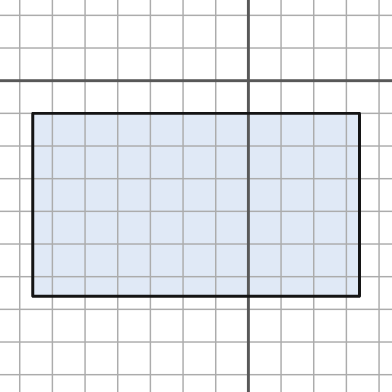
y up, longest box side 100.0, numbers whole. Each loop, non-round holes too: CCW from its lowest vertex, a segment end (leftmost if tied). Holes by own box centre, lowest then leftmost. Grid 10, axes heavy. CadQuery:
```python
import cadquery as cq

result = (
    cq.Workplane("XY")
    .moveTo(-66.0, -66.0)
    .lineTo(34.0, -66.0)
    .lineTo(34.0, -10.0)
    .lineTo(-66.0, -10.0)
    .close()
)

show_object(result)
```